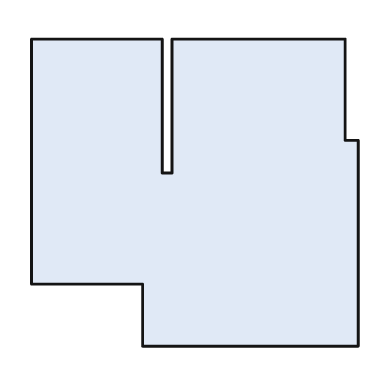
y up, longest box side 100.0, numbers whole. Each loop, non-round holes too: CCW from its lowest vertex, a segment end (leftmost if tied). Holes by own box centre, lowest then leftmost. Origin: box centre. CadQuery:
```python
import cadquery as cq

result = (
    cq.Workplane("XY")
    .moveTo(-16.0, -47.0)
    .lineTo(50.0, -47.0)
    .lineTo(50.0, 16.0)
    .lineTo(46.0, 16.0)
    .lineTo(46.0, 47.0)
    .lineTo(-7.0, 47.0)
    .lineTo(-7.0, 6.0)
    .lineTo(-10.0, 6.0)
    .lineTo(-10.0, 47.0)
    .lineTo(-50.0, 47.0)
    .lineTo(-50.0, -28.0)
    .lineTo(-16.0, -28.0)
    .close()
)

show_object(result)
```